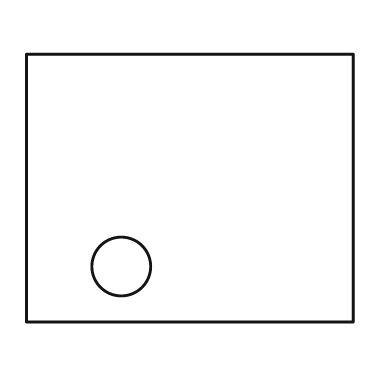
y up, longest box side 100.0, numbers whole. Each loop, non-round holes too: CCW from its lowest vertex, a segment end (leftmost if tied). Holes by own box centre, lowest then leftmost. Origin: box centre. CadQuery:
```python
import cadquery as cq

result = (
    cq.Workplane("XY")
    .moveTo(-50.0, -41.0)
    .lineTo(50.0, -41.0)
    .lineTo(50.0, 41.0)
    .lineTo(-50.0, 41.0)
    .close()
    .moveTo(-21.0, -24.0)
    .circle(9.0)
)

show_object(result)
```